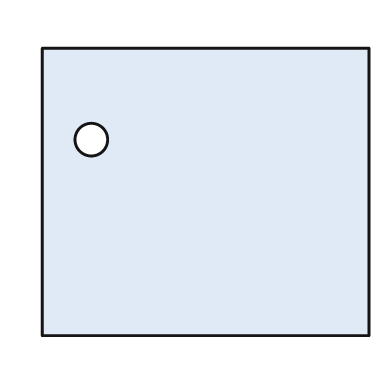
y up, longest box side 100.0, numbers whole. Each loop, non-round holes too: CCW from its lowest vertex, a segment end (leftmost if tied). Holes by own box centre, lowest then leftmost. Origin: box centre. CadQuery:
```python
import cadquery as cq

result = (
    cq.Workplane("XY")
    .moveTo(-50.0, -44.0)
    .lineTo(50.0, -44.0)
    .lineTo(50.0, 44.0)
    .lineTo(-50.0, 44.0)
    .close()
    .moveTo(-35.0, 16.0)
    .circle(5.0)
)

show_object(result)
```